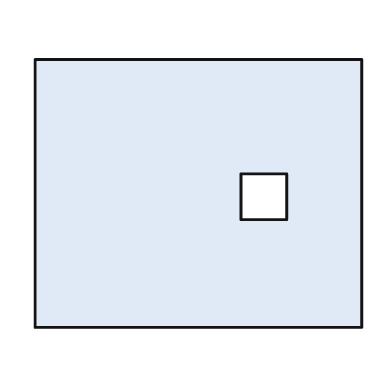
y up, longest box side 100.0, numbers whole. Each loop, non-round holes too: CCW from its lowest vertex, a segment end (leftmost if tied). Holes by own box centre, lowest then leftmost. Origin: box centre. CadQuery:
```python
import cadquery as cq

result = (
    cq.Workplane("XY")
    .moveTo(-50.0, -41.0)
    .lineTo(50.0, -41.0)
    .lineTo(50.0, 41.0)
    .lineTo(-50.0, 41.0)
    .close()
    .moveTo(13.0, -8.0)
    .lineTo(27.0, -8.0)
    .lineTo(27.0, 6.0)
    .lineTo(13.0, 6.0)
    .close()
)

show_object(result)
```